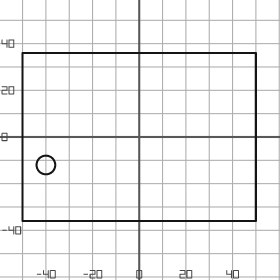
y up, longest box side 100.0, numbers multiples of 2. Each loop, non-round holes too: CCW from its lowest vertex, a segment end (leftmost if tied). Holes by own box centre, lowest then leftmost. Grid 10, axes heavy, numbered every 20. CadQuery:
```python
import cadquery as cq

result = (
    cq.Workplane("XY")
    .moveTo(-50.0, -36.0)
    .lineTo(50.0, -36.0)
    .lineTo(50.0, 36.0)
    .lineTo(-50.0, 36.0)
    .close()
    .moveTo(-40.0, -12.0)
    .circle(4.0)
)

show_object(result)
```